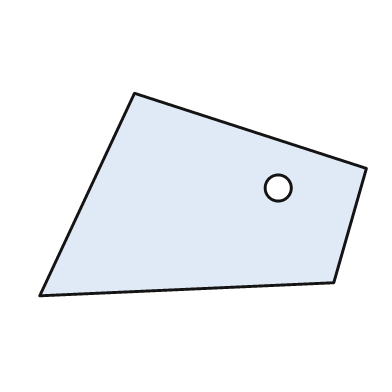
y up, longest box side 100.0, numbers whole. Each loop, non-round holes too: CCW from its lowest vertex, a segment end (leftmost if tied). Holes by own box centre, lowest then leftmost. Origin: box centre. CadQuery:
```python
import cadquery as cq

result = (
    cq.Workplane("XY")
    .moveTo(-50.0, -31.0)
    .lineTo(40.0, -27.0)
    .lineTo(50.0, 8.0)
    .lineTo(-21.0, 31.0)
    .close()
    .moveTo(23.0, 2.0)
    .circle(4.0)
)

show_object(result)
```